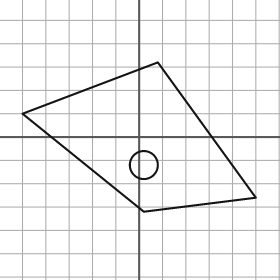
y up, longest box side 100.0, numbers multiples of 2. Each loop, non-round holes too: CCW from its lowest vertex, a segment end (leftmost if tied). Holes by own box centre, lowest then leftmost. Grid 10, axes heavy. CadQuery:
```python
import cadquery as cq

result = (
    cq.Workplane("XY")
    .moveTo(2.0, -32.0)
    .lineTo(50.0, -26.0)
    .lineTo(8.0, 32.0)
    .lineTo(-50.0, 10.0)
    .close()
    .moveTo(2.0, -12.0)
    .circle(6.0)
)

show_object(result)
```